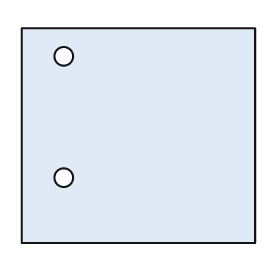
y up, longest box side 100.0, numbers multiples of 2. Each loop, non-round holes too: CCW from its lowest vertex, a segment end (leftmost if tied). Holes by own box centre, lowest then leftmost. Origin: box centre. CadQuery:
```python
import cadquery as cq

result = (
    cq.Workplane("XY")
    .moveTo(-50.0, -46.0)
    .lineTo(50.0, -46.0)
    .lineTo(50.0, 46.0)
    .lineTo(-50.0, 46.0)
    .close()
    .moveTo(-32.0, -18.0)
    .circle(4.0)
    .moveTo(-32.0, 34.0)
    .circle(4.0)
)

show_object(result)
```